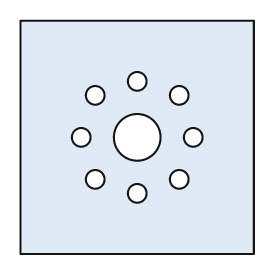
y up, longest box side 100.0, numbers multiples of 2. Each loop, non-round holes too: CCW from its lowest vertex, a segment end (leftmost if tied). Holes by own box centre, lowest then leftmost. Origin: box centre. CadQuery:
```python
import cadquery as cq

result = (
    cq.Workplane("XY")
    .moveTo(-50.0, -50.0)
    .lineTo(50.0, -50.0)
    .lineTo(50.0, 50.0)
    .lineTo(-50.0, 50.0)
    .close()
    .moveTo(0.0, -24.0)
    .circle(4.0)
    .moveTo(-18.0, -18.0)
    .circle(4.0)
    .moveTo(18.0, -18.0)
    .circle(4.0)
    .moveTo(-24.0, 0.0)
    .circle(4.0)
    .moveTo(0.0, 0.0)
    .circle(10.0)
    .moveTo(24.0, 0.0)
    .circle(4.0)
    .moveTo(-18.0, 18.0)
    .circle(4.0)
    .moveTo(18.0, 18.0)
    .circle(4.0)
    .moveTo(0.0, 24.0)
    .circle(4.0)
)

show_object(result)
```